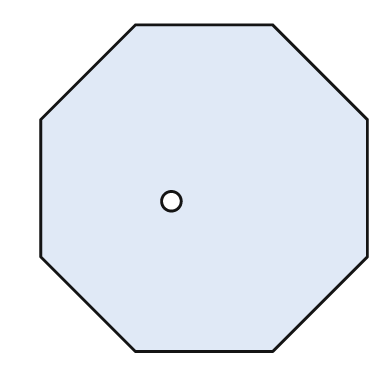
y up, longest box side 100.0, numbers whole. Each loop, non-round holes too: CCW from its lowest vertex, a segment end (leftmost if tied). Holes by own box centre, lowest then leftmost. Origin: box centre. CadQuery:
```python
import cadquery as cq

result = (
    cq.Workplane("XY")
    .moveTo(-21.0, -50.0)
    .lineTo(21.0, -50.0)
    .lineTo(50.0, -21.0)
    .lineTo(50.0, 21.0)
    .lineTo(21.0, 50.0)
    .lineTo(-21.0, 50.0)
    .lineTo(-50.0, 21.0)
    .lineTo(-50.0, -21.0)
    .close()
    .moveTo(-10.0, -4.0)
    .circle(3.0)
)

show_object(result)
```